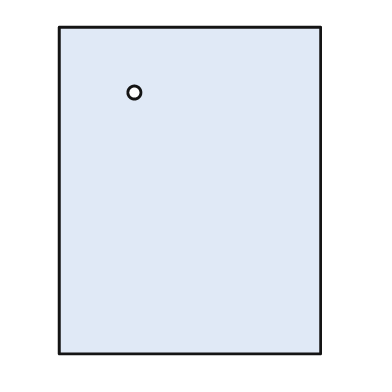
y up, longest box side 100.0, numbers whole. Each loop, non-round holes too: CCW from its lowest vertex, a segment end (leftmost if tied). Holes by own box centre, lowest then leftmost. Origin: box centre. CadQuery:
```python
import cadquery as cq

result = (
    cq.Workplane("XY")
    .moveTo(-40.0, -50.0)
    .lineTo(40.0, -50.0)
    .lineTo(40.0, 50.0)
    .lineTo(-40.0, 50.0)
    .close()
    .moveTo(-17.0, 30.0)
    .circle(2.0)
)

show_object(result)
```